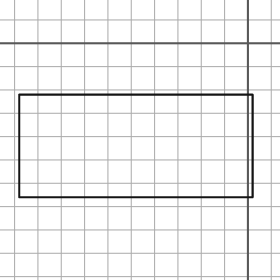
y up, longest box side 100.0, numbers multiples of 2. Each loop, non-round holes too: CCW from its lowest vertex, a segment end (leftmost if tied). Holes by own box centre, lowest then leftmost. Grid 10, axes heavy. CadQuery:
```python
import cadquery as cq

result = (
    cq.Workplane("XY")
    .moveTo(-98.0, -66.0)
    .lineTo(2.0, -66.0)
    .lineTo(2.0, -22.0)
    .lineTo(-98.0, -22.0)
    .close()
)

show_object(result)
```